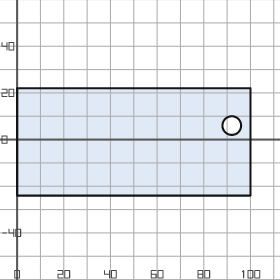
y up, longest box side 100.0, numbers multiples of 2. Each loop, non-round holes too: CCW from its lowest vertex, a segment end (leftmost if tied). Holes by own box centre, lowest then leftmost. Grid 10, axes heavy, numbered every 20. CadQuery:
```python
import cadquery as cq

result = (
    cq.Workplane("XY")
    .moveTo(0.0, -24.0)
    .lineTo(100.0, -24.0)
    .lineTo(100.0, 22.0)
    .lineTo(0.0, 22.0)
    .close()
    .moveTo(92.0, 6.0)
    .circle(4.0)
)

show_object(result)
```